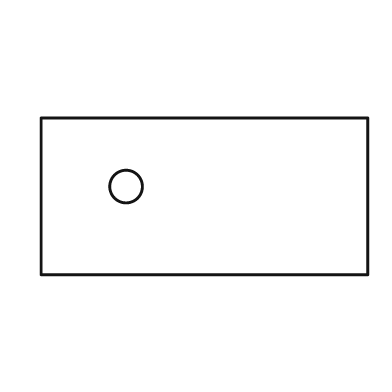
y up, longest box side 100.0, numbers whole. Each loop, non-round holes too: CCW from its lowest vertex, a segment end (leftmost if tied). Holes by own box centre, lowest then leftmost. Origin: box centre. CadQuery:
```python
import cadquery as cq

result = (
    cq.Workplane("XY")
    .moveTo(-50.0, -24.0)
    .lineTo(50.0, -24.0)
    .lineTo(50.0, 24.0)
    .lineTo(-50.0, 24.0)
    .close()
    .moveTo(-24.0, 3.0)
    .circle(5.0)
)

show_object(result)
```